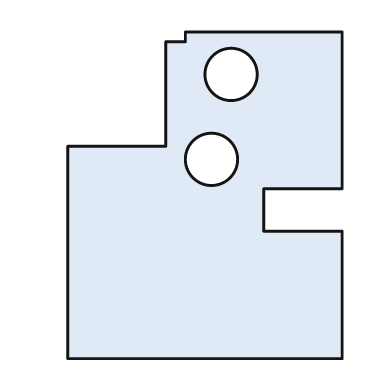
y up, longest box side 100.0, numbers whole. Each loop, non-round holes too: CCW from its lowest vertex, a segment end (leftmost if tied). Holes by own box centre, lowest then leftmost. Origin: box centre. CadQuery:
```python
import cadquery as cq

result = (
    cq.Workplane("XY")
    .moveTo(-42.0, -50.0)
    .lineTo(42.0, -50.0)
    .lineTo(42.0, -11.0)
    .lineTo(18.0, -11.0)
    .lineTo(18.0, 2.0)
    .lineTo(42.0, 2.0)
    .lineTo(42.0, 50.0)
    .lineTo(-6.0, 50.0)
    .lineTo(-6.0, 47.0)
    .lineTo(-12.0, 47.0)
    .lineTo(-12.0, 15.0)
    .lineTo(-42.0, 15.0)
    .close()
    .moveTo(2.0, 11.0)
    .circle(8.0)
    .moveTo(8.0, 37.0)
    .circle(8.0)
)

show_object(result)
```